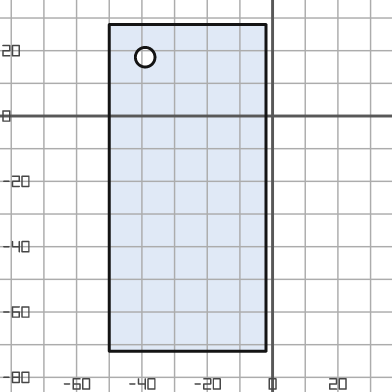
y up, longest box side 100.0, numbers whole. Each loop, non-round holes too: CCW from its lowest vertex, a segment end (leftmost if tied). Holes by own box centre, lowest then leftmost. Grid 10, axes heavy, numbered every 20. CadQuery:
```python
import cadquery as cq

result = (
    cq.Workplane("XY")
    .moveTo(-50.0, -72.0)
    .lineTo(-2.0, -72.0)
    .lineTo(-2.0, 28.0)
    .lineTo(-50.0, 28.0)
    .close()
    .moveTo(-39.0, 18.0)
    .circle(3.0)
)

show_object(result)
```